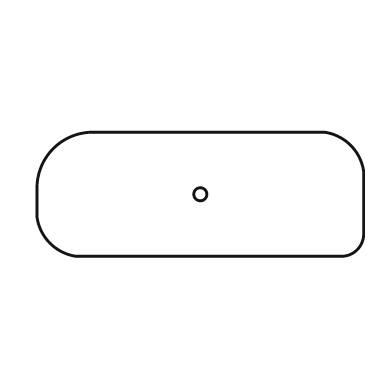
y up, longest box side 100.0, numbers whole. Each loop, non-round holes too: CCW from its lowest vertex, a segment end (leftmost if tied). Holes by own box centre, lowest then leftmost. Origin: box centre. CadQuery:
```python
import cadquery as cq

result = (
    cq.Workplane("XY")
    .moveTo(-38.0, -19.0)
    .lineTo(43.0, -19.0)
    .threePointArc((48.0, -17.0), (50.0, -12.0))
    .lineTo(50.0, 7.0)
    .threePointArc((46.0, 15.0), (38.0, 19.0))
    .lineTo(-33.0, 19.0)
    .threePointArc((-45.0, 14.0), (-50.0, 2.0))
    .lineTo(-50.0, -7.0)
    .threePointArc((-46.0, -15.0), (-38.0, -19.0))
    .close()
    .moveTo(0.0, 0.0)
    .circle(2.0)
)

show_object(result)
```